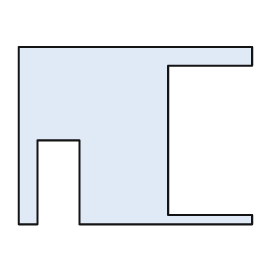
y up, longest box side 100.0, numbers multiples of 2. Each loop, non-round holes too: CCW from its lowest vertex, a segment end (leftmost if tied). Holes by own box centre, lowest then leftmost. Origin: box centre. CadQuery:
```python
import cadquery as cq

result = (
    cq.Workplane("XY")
    .moveTo(-50.0, -38.0)
    .lineTo(-42.0, -38.0)
    .lineTo(-42.0, -2.0)
    .lineTo(-24.0, -2.0)
    .lineTo(-24.0, -38.0)
    .lineTo(50.0, -38.0)
    .lineTo(50.0, -34.0)
    .lineTo(14.0, -34.0)
    .lineTo(14.0, 30.0)
    .lineTo(50.0, 30.0)
    .lineTo(50.0, 38.0)
    .lineTo(-50.0, 38.0)
    .close()
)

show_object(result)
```